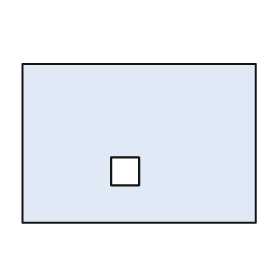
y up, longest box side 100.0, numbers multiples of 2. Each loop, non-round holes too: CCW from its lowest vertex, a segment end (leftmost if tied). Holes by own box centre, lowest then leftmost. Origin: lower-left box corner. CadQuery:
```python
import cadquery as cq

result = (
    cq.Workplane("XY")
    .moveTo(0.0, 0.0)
    .lineTo(100.0, 0.0)
    .lineTo(100.0, 68.0)
    .lineTo(0.0, 68.0)
    .close()
    .moveTo(38.0, 16.0)
    .lineTo(50.0, 16.0)
    .lineTo(50.0, 28.0)
    .lineTo(38.0, 28.0)
    .close()
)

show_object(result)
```